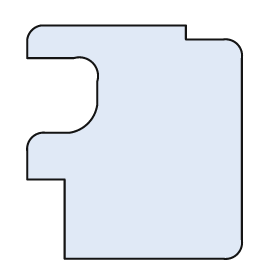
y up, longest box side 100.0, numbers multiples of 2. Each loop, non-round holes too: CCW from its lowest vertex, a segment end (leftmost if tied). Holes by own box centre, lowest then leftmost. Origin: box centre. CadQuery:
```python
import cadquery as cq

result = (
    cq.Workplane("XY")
    .moveTo(-30.0, -50.0)
    .lineTo(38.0, -50.0)
    .threePointArc((44.0, -48.0), (46.0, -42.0))
    .lineTo(46.0, 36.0)
    .threePointArc((44.0, 42.0), (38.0, 44.0))
    .lineTo(22.0, 44.0)
    .lineTo(22.0, 50.0)
    .lineTo(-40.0, 50.0)
    .threePointArc((-44.0, 48.0), (-46.0, 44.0))
    .lineTo(-46.0, 36.0)
    .lineTo(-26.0, 36.0)
    .threePointArc((-18.0, 34.0), (-16.0, 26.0))
    .lineTo(-16.0, 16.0)
    .threePointArc((-20.0, 8.0), (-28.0, 4.0))
    .lineTo(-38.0, 4.0)
    .threePointArc((-44.0, 2.0), (-46.0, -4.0))
    .lineTo(-46.0, -16.0)
    .lineTo(-30.0, -16.0)
    .close()
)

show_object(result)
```